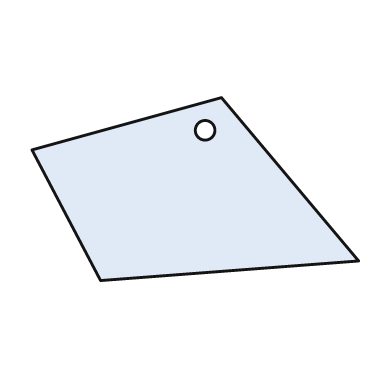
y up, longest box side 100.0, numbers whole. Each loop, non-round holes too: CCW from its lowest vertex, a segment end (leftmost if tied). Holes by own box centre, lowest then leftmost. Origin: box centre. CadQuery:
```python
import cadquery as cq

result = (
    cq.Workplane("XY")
    .moveTo(-29.0, -28.0)
    .lineTo(50.0, -22.0)
    .lineTo(8.0, 28.0)
    .lineTo(-50.0, 12.0)
    .close()
    .moveTo(3.0, 18.0)
    .circle(3.0)
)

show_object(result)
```